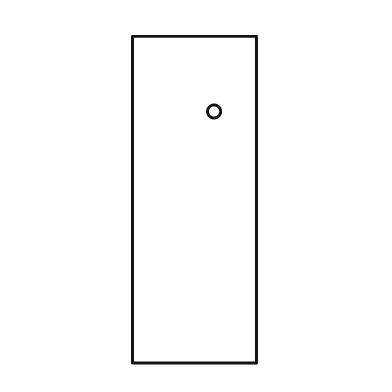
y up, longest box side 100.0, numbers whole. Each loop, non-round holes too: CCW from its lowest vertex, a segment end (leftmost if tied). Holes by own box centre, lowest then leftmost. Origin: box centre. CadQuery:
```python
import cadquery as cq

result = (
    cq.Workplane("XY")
    .moveTo(-19.0, -50.0)
    .lineTo(19.0, -50.0)
    .lineTo(19.0, 50.0)
    .lineTo(-19.0, 50.0)
    .close()
    .moveTo(6.0, 27.0)
    .circle(2.0)
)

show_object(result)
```